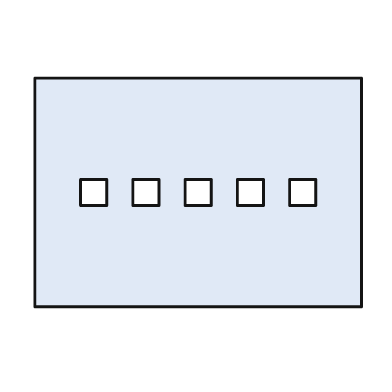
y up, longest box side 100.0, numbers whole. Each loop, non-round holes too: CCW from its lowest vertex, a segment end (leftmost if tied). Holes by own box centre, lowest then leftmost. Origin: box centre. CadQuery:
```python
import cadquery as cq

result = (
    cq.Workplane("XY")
    .moveTo(-50.0, -35.0)
    .lineTo(50.0, -35.0)
    .lineTo(50.0, 35.0)
    .lineTo(-50.0, 35.0)
    .close()
    .moveTo(-36.0, -4.0)
    .lineTo(-28.0, -4.0)
    .lineTo(-28.0, 4.0)
    .lineTo(-36.0, 4.0)
    .close()
    .moveTo(-20.0, -4.0)
    .lineTo(-12.0, -4.0)
    .lineTo(-12.0, 4.0)
    .lineTo(-20.0, 4.0)
    .close()
    .moveTo(-4.0, -4.0)
    .lineTo(4.0, -4.0)
    .lineTo(4.0, 4.0)
    .lineTo(-4.0, 4.0)
    .close()
    .moveTo(12.0, -4.0)
    .lineTo(20.0, -4.0)
    .lineTo(20.0, 4.0)
    .lineTo(12.0, 4.0)
    .close()
    .moveTo(28.0, -4.0)
    .lineTo(36.0, -4.0)
    .lineTo(36.0, 4.0)
    .lineTo(28.0, 4.0)
    .close()
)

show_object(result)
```